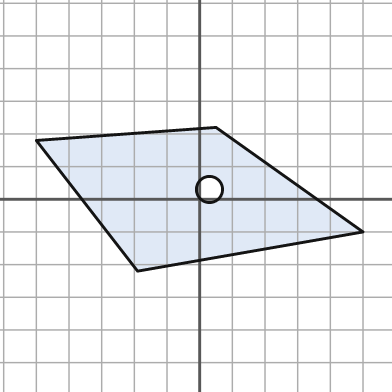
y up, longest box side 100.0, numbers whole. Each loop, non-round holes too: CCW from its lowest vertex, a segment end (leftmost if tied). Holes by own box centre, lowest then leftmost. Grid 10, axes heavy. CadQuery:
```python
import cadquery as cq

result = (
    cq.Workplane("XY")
    .moveTo(-19.0, -22.0)
    .lineTo(50.0, -10.0)
    .lineTo(5.0, 22.0)
    .lineTo(-50.0, 18.0)
    .close()
    .moveTo(3.0, 3.0)
    .circle(4.0)
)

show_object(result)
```